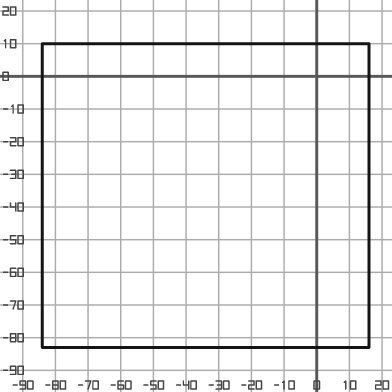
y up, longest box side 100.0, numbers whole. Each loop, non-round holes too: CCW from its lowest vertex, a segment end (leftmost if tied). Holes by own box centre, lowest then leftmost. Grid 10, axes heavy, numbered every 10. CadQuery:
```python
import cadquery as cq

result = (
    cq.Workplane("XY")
    .moveTo(-84.0, -83.0)
    .lineTo(16.0, -83.0)
    .lineTo(16.0, 10.0)
    .lineTo(-84.0, 10.0)
    .close()
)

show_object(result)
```